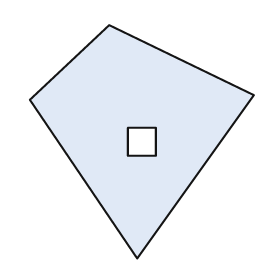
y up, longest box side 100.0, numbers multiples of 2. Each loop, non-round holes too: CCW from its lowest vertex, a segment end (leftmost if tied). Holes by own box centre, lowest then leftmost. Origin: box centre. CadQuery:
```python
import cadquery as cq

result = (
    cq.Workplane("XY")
    .moveTo(-2.0, -50.0)
    .lineTo(48.0, 20.0)
    .lineTo(-14.0, 50.0)
    .lineTo(-48.0, 18.0)
    .close()
    .moveTo(-6.0, -6.0)
    .lineTo(6.0, -6.0)
    .lineTo(6.0, 6.0)
    .lineTo(-6.0, 6.0)
    .close()
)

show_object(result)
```